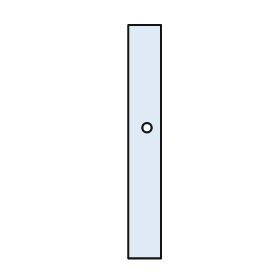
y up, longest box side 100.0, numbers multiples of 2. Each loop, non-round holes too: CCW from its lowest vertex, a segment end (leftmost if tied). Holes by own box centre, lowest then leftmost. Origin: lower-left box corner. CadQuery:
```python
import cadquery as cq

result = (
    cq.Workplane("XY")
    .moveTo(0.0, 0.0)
    .lineTo(14.0, 0.0)
    .lineTo(14.0, 100.0)
    .lineTo(0.0, 100.0)
    .close()
    .moveTo(8.0, 56.0)
    .circle(2.0)
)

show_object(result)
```